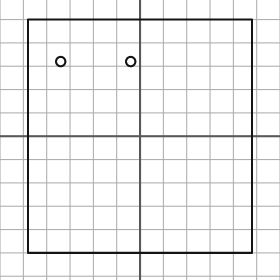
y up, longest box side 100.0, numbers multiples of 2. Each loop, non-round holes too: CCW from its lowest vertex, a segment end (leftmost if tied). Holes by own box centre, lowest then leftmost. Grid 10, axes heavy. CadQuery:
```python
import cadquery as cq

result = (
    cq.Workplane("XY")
    .moveTo(-48.0, -50.0)
    .lineTo(48.0, -50.0)
    .lineTo(48.0, 50.0)
    .lineTo(-48.0, 50.0)
    .close()
    .moveTo(-34.0, 32.0)
    .circle(2.0)
    .moveTo(-4.0, 32.0)
    .circle(2.0)
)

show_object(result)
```